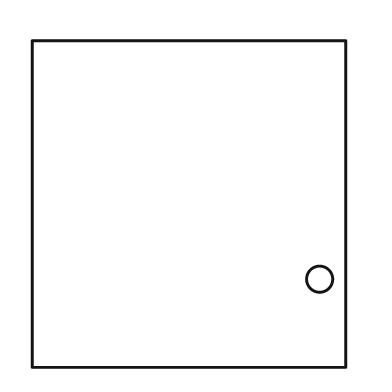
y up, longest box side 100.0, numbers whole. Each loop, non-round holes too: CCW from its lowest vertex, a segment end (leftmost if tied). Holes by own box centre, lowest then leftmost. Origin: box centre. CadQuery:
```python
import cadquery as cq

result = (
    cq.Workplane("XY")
    .moveTo(-48.0, -50.0)
    .lineTo(48.0, -50.0)
    .lineTo(48.0, 50.0)
    .lineTo(-48.0, 50.0)
    .close()
    .moveTo(40.0, -23.0)
    .circle(4.0)
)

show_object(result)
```